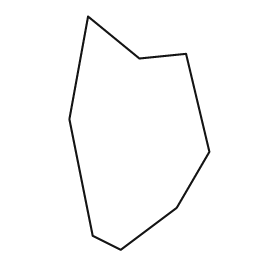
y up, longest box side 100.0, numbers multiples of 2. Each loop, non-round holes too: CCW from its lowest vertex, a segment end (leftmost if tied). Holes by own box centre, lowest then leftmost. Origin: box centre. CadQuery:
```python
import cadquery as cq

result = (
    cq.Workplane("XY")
    .moveTo(-8.0, -50.0)
    .lineTo(16.0, -32.0)
    .lineTo(30.0, -8.0)
    .lineTo(20.0, 34.0)
    .lineTo(0.0, 32.0)
    .lineTo(-22.0, 50.0)
    .lineTo(-30.0, 6.0)
    .lineTo(-20.0, -44.0)
    .close()
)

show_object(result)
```